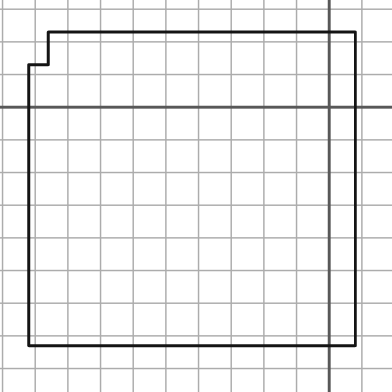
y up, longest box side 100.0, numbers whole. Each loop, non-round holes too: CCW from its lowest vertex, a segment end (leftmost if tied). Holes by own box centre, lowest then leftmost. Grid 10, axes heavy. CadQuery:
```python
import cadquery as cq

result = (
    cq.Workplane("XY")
    .moveTo(-92.0, -73.0)
    .lineTo(8.0, -73.0)
    .lineTo(8.0, 23.0)
    .lineTo(-86.0, 23.0)
    .lineTo(-86.0, 13.0)
    .lineTo(-92.0, 13.0)
    .close()
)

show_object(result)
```